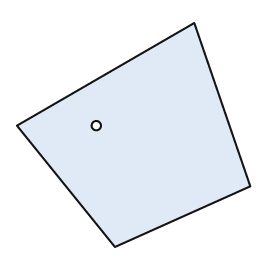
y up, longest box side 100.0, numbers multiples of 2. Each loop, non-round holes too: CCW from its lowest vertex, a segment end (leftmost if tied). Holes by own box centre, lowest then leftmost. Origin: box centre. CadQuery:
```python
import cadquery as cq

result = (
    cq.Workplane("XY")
    .moveTo(-8.0, -48.0)
    .lineTo(50.0, -22.0)
    .lineTo(26.0, 48.0)
    .lineTo(-50.0, 4.0)
    .close()
    .moveTo(-16.0, 4.0)
    .circle(2.0)
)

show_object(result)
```